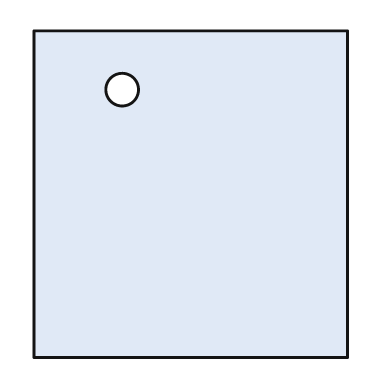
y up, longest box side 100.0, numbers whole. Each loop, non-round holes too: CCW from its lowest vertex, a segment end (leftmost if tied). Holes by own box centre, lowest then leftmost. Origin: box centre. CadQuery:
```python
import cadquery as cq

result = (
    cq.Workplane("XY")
    .moveTo(-48.0, -50.0)
    .lineTo(48.0, -50.0)
    .lineTo(48.0, 50.0)
    .lineTo(-48.0, 50.0)
    .close()
    .moveTo(-21.0, 32.0)
    .circle(5.0)
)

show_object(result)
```